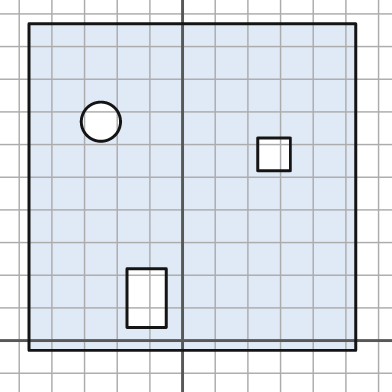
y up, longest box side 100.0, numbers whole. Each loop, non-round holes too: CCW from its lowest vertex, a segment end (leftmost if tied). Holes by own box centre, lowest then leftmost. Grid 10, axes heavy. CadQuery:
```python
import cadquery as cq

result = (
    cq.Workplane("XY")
    .moveTo(-47.0, -3.0)
    .lineTo(53.0, -3.0)
    .lineTo(53.0, 97.0)
    .lineTo(-47.0, 97.0)
    .close()
    .moveTo(-17.0, 4.0)
    .lineTo(-5.0, 4.0)
    .lineTo(-5.0, 22.0)
    .lineTo(-17.0, 22.0)
    .close()
    .moveTo(23.0, 52.0)
    .lineTo(33.0, 52.0)
    .lineTo(33.0, 62.0)
    .lineTo(23.0, 62.0)
    .close()
    .moveTo(-25.0, 67.0)
    .circle(6.0)
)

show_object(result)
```